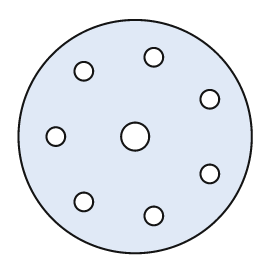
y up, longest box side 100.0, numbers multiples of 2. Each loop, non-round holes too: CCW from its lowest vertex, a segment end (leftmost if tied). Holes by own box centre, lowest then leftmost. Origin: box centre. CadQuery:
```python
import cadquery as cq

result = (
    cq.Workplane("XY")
    .moveTo(0.0, 0.0)
    .circle(50.0)
    .moveTo(8.0, -34.0)
    .circle(4.0)
    .moveTo(-22.0, -28.0)
    .circle(4.0)
    .moveTo(32.0, -16.0)
    .circle(4.0)
    .moveTo(-34.0, 0.0)
    .circle(4.0)
    .moveTo(0.0, 0.0)
    .circle(6.0)
    .moveTo(32.0, 16.0)
    .circle(4.0)
    .moveTo(-22.0, 28.0)
    .circle(4.0)
    .moveTo(8.0, 34.0)
    .circle(4.0)
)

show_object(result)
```